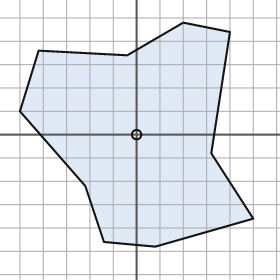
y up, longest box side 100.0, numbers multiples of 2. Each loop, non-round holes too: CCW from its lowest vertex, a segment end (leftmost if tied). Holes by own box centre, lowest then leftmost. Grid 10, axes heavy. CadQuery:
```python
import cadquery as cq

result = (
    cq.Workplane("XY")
    .moveTo(8.0, -48.0)
    .lineTo(50.0, -36.0)
    .lineTo(32.0, -8.0)
    .lineTo(40.0, 44.0)
    .lineTo(20.0, 48.0)
    .lineTo(-4.0, 34.0)
    .lineTo(-42.0, 36.0)
    .lineTo(-50.0, 10.0)
    .lineTo(-22.0, -22.0)
    .lineTo(-14.0, -46.0)
    .close()
    .moveTo(0.0, 0.0)
    .circle(2.0)
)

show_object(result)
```